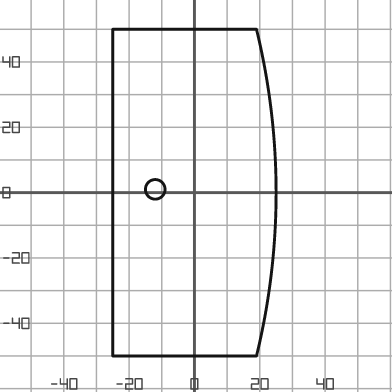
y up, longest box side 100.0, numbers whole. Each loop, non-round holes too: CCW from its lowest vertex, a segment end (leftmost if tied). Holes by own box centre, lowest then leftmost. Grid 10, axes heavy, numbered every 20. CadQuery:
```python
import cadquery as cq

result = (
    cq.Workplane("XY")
    .moveTo(-25.0, -50.0)
    .lineTo(19.0, -50.0)
    .threePointArc((25.0, 0.0), (19.0, 50.0))
    .lineTo(-25.0, 50.0)
    .close()
    .moveTo(-12.0, 1.0)
    .circle(3.0)
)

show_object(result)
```